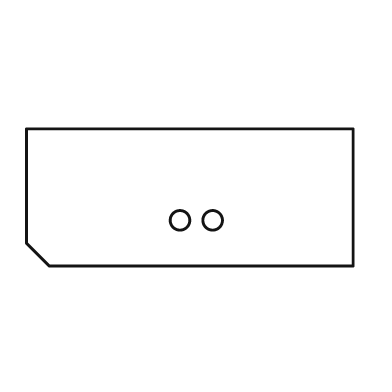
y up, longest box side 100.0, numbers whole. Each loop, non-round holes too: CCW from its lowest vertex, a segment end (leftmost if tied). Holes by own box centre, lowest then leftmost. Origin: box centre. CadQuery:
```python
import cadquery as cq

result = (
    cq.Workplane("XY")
    .moveTo(-43.0, -21.0)
    .lineTo(50.0, -21.0)
    .lineTo(50.0, 21.0)
    .lineTo(-50.0, 21.0)
    .lineTo(-50.0, -14.0)
    .close()
    .moveTo(-3.0, -7.0)
    .circle(3.0)
    .moveTo(7.0, -7.0)
    .circle(3.0)
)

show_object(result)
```